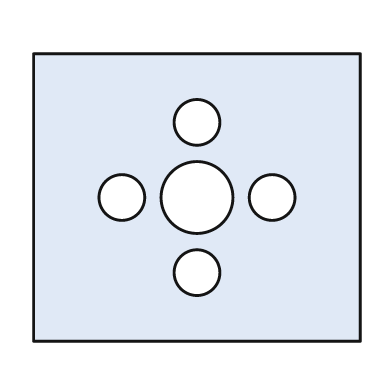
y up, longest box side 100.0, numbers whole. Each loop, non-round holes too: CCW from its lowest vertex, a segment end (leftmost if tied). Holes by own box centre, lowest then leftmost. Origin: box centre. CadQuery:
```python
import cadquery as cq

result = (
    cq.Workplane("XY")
    .moveTo(-50.0, -44.0)
    .lineTo(50.0, -44.0)
    .lineTo(50.0, 44.0)
    .lineTo(-50.0, 44.0)
    .close()
    .moveTo(0.0, -23.0)
    .circle(7.0)
    .moveTo(-23.0, 0.0)
    .circle(7.0)
    .moveTo(0.0, 0.0)
    .circle(11.0)
    .moveTo(23.0, 0.0)
    .circle(7.0)
    .moveTo(0.0, 23.0)
    .circle(7.0)
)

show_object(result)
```